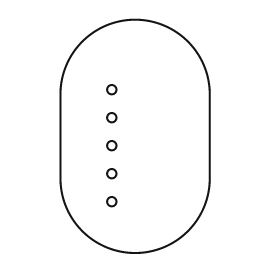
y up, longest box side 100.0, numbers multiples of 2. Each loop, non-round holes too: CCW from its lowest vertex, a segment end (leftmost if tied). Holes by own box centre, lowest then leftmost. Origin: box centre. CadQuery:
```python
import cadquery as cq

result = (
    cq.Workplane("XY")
    .moveTo(-32.0, -18.0)
    .threePointArc((0.0, -50.0), (32.0, -18.0))
    .lineTo(32.0, 18.0)
    .threePointArc((0.0, 50.0), (-32.0, 18.0))
    .close()
    .moveTo(-10.0, -28.0)
    .circle(2.0)
    .moveTo(-10.0, -16.0)
    .circle(2.0)
    .moveTo(-10.0, -4.0)
    .circle(2.0)
    .moveTo(-10.0, 8.0)
    .circle(2.0)
    .moveTo(-10.0, 20.0)
    .circle(2.0)
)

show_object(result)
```